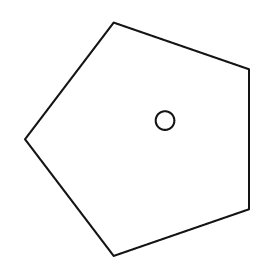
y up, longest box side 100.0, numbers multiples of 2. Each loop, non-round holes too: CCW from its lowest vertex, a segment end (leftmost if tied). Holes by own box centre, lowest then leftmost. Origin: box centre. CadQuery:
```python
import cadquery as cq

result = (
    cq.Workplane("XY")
    .moveTo(-10.0, -50.0)
    .lineTo(48.0, -30.0)
    .lineTo(48.0, 30.0)
    .lineTo(-10.0, 50.0)
    .lineTo(-48.0, 0.0)
    .close()
    .moveTo(12.0, 8.0)
    .circle(4.0)
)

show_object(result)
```